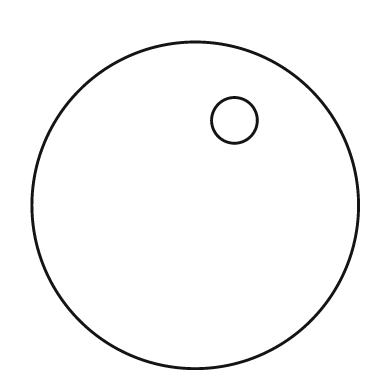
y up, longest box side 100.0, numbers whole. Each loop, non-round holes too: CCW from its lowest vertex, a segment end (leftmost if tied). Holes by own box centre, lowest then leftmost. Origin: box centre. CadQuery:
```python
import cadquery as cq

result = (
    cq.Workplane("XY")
    .moveTo(0.0, 0.0)
    .circle(50.0)
    .moveTo(12.0, 26.0)
    .circle(7.0)
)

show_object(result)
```